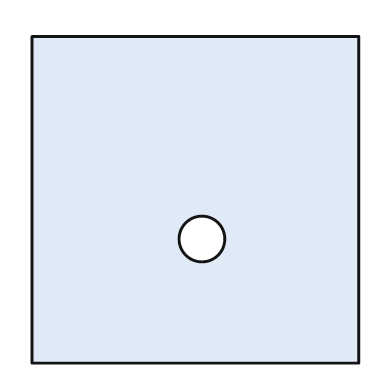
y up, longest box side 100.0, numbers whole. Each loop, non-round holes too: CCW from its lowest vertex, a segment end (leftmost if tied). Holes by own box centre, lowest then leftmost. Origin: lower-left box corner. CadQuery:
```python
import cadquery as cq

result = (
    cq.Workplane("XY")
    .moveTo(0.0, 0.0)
    .lineTo(100.0, 0.0)
    .lineTo(100.0, 100.0)
    .lineTo(0.0, 100.0)
    .close()
    .moveTo(52.0, 38.0)
    .circle(7.0)
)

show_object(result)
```